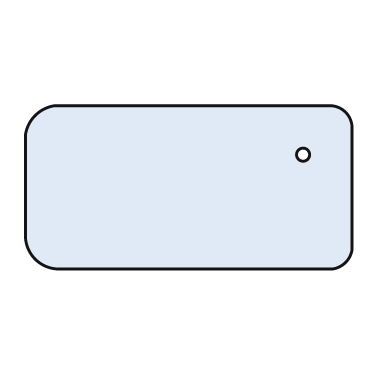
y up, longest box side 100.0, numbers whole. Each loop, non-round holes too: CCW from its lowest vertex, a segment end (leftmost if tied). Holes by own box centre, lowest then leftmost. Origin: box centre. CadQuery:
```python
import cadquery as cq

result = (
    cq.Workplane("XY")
    .moveTo(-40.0, -25.0)
    .lineTo(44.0, -25.0)
    .threePointArc((48.0, -23.0), (50.0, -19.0))
    .lineTo(50.0, 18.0)
    .threePointArc((48.0, 23.0), (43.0, 25.0))
    .lineTo(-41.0, 25.0)
    .threePointArc((-47.0, 22.0), (-50.0, 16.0))
    .lineTo(-50.0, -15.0)
    .threePointArc((-47.0, -22.0), (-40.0, -25.0))
    .close()
    .moveTo(35.0, 10.0)
    .circle(2.0)
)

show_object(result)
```